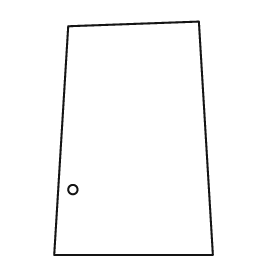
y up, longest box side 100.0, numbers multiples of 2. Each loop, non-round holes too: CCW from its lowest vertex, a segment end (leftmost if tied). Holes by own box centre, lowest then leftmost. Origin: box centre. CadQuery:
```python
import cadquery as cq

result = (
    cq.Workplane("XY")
    .moveTo(-34.0, -50.0)
    .lineTo(34.0, -50.0)
    .lineTo(28.0, 50.0)
    .lineTo(-28.0, 48.0)
    .close()
    .moveTo(-26.0, -22.0)
    .circle(2.0)
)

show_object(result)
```